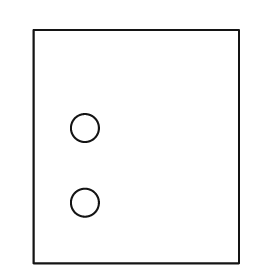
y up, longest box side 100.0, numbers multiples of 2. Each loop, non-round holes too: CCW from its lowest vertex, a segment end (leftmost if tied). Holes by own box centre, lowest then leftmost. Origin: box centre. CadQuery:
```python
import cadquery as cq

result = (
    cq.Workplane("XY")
    .moveTo(-44.0, -50.0)
    .lineTo(44.0, -50.0)
    .lineTo(44.0, 50.0)
    .lineTo(-44.0, 50.0)
    .close()
    .moveTo(-22.0, -24.0)
    .circle(6.0)
    .moveTo(-22.0, 8.0)
    .circle(6.0)
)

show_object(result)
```